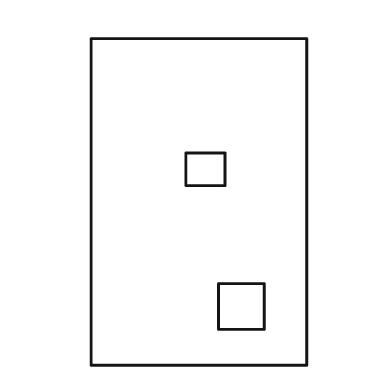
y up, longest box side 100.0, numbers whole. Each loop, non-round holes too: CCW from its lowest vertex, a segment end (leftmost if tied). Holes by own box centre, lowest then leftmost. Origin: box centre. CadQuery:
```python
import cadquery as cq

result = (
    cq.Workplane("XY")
    .moveTo(-33.0, -50.0)
    .lineTo(33.0, -50.0)
    .lineTo(33.0, 50.0)
    .lineTo(-33.0, 50.0)
    .close()
    .moveTo(6.0, -39.0)
    .lineTo(20.0, -39.0)
    .lineTo(20.0, -25.0)
    .lineTo(6.0, -25.0)
    .close()
    .moveTo(-4.0, 5.0)
    .lineTo(8.0, 5.0)
    .lineTo(8.0, 15.0)
    .lineTo(-4.0, 15.0)
    .close()
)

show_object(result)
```